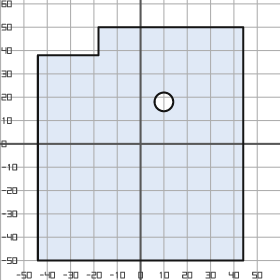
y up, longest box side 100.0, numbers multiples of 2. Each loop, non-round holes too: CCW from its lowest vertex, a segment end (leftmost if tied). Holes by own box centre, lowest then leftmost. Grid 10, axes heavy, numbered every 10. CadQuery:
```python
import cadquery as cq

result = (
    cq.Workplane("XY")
    .moveTo(-44.0, -50.0)
    .lineTo(44.0, -50.0)
    .lineTo(44.0, 50.0)
    .lineTo(-18.0, 50.0)
    .lineTo(-18.0, 38.0)
    .lineTo(-44.0, 38.0)
    .close()
    .moveTo(10.0, 18.0)
    .circle(4.0)
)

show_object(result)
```